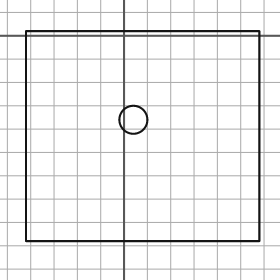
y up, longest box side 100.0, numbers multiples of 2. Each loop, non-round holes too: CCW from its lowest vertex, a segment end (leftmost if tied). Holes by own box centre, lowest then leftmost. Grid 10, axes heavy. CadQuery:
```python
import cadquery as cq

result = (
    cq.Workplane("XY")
    .moveTo(-42.0, -88.0)
    .lineTo(58.0, -88.0)
    .lineTo(58.0, 2.0)
    .lineTo(-42.0, 2.0)
    .close()
    .moveTo(4.0, -36.0)
    .circle(6.0)
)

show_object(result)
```